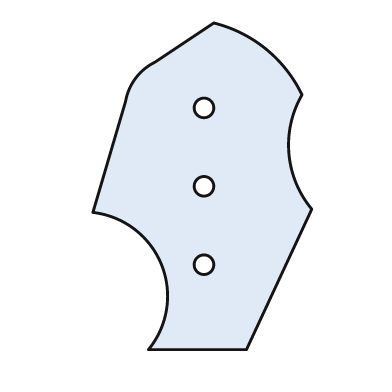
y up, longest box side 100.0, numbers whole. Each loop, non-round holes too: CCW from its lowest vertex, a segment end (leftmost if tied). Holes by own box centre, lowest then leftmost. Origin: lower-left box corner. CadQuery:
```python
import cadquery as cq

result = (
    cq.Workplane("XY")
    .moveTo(17.0, 0.0)
    .lineTo(47.0, 0.0)
    .lineTo(67.0, 43.0)
    .threePointArc((60.0, 60.0), (64.0, 78.0))
    .threePointArc((53.0, 92.0), (37.0, 100.0))
    .lineTo(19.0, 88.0)
    .threePointArc((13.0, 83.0), (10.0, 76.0))
    .lineTo(0.0, 42.0)
    .threePointArc((21.0, 26.0), (17.0, 0.0))
    .close()
    .moveTo(34.0, 26.0)
    .circle(3.0)
    .moveTo(34.0, 50.0)
    .circle(3.0)
    .moveTo(34.0, 74.0)
    .circle(3.0)
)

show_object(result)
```